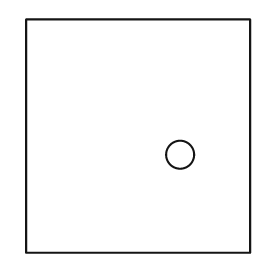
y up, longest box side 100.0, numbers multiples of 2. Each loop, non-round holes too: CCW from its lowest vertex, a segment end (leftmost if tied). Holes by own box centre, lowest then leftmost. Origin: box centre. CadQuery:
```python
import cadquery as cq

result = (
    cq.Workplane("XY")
    .moveTo(-48.0, -50.0)
    .lineTo(48.0, -50.0)
    .lineTo(48.0, 50.0)
    .lineTo(-48.0, 50.0)
    .close()
    .moveTo(18.0, -8.0)
    .circle(6.0)
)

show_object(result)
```